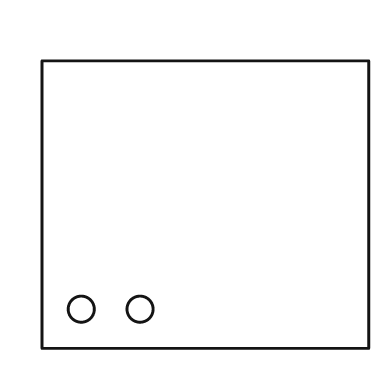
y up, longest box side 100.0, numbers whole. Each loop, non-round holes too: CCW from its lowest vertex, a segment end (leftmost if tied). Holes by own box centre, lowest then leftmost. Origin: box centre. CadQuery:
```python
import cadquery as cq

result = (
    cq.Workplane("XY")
    .moveTo(-50.0, -44.0)
    .lineTo(50.0, -44.0)
    .lineTo(50.0, 44.0)
    .lineTo(-50.0, 44.0)
    .close()
    .moveTo(-38.0, -32.0)
    .circle(4.0)
    .moveTo(-20.0, -32.0)
    .circle(4.0)
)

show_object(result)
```